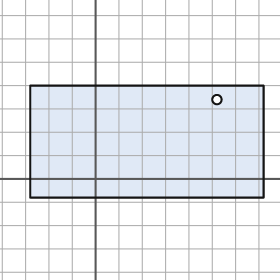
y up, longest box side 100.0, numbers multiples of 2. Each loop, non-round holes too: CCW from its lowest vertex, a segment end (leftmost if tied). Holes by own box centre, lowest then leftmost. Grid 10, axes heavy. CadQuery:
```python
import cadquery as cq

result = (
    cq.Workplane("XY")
    .moveTo(-28.0, -8.0)
    .lineTo(72.0, -8.0)
    .lineTo(72.0, 40.0)
    .lineTo(-28.0, 40.0)
    .close()
    .moveTo(52.0, 34.0)
    .circle(2.0)
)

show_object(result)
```